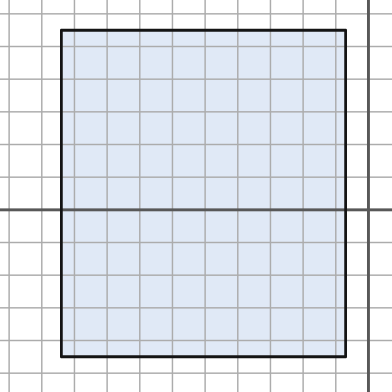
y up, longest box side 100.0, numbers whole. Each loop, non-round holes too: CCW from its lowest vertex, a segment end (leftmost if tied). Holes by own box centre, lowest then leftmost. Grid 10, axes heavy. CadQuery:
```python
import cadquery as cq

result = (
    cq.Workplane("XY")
    .moveTo(-94.0, -45.0)
    .lineTo(-7.0, -45.0)
    .lineTo(-7.0, 55.0)
    .lineTo(-94.0, 55.0)
    .close()
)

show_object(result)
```